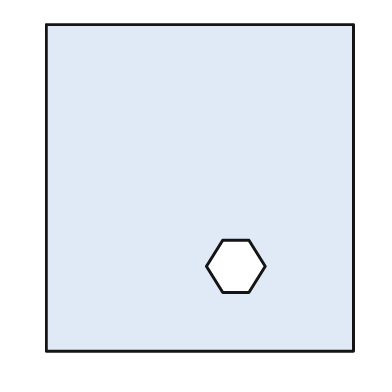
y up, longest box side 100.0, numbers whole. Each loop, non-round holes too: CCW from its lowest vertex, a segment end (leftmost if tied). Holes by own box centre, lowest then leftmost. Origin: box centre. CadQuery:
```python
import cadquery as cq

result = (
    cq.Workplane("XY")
    .moveTo(-47.0, -50.0)
    .lineTo(47.0, -50.0)
    .lineTo(47.0, 50.0)
    .lineTo(-47.0, 50.0)
    .close()
    .moveTo(7.0, -32.0)
    .lineTo(15.0, -32.0)
    .lineTo(20.0, -24.0)
    .lineTo(15.0, -16.0)
    .lineTo(7.0, -16.0)
    .lineTo(2.0, -24.0)
    .close()
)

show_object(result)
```